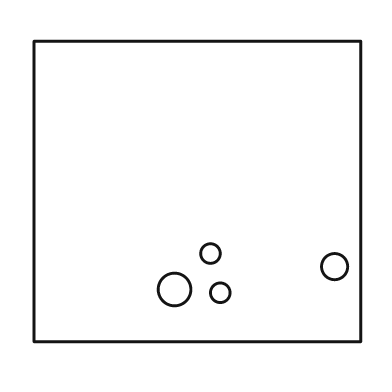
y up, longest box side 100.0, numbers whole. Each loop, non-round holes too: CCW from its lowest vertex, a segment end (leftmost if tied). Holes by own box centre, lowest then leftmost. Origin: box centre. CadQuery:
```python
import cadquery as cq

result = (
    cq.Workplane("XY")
    .moveTo(-50.0, -46.0)
    .lineTo(50.0, -46.0)
    .lineTo(50.0, 46.0)
    .lineTo(-50.0, 46.0)
    .close()
    .moveTo(7.0, -31.0)
    .circle(3.0)
    .moveTo(-7.0, -30.0)
    .circle(5.0)
    .moveTo(42.0, -23.0)
    .circle(4.0)
    .moveTo(4.0, -19.0)
    .circle(3.0)
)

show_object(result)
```